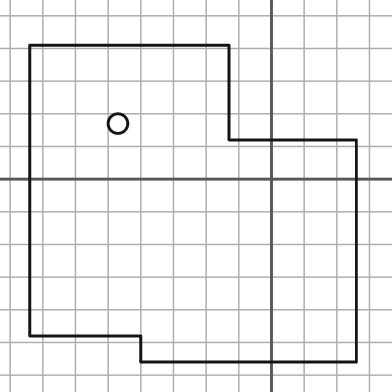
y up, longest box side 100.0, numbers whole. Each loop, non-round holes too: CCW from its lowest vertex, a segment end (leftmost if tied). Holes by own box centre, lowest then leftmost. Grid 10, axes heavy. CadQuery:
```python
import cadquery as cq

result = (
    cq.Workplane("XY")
    .moveTo(-40.0, -56.0)
    .lineTo(26.0, -56.0)
    .lineTo(26.0, 12.0)
    .lineTo(-13.0, 12.0)
    .lineTo(-13.0, 41.0)
    .lineTo(-74.0, 41.0)
    .lineTo(-74.0, -48.0)
    .lineTo(-40.0, -48.0)
    .close()
    .moveTo(-47.0, 17.0)
    .circle(3.0)
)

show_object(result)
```